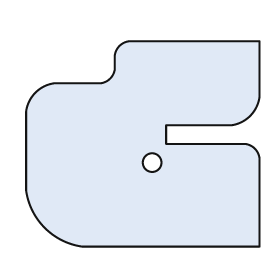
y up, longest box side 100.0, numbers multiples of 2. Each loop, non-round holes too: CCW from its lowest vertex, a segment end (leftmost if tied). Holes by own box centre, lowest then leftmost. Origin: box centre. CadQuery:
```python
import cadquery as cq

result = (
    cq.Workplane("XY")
    .moveTo(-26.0, -44.0)
    .lineTo(50.0, -44.0)
    .lineTo(50.0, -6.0)
    .threePointArc((48.0, -2.0), (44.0, 0.0))
    .lineTo(10.0, 0.0)
    .lineTo(10.0, 8.0)
    .lineTo(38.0, 8.0)
    .threePointArc((46.0, 12.0), (50.0, 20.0))
    .lineTo(50.0, 44.0)
    .lineTo(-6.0, 44.0)
    .threePointArc((-10.0, 42.0), (-12.0, 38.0))
    .lineTo(-12.0, 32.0)
    .threePointArc((-14.0, 28.0), (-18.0, 26.0))
    .lineTo(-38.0, 26.0)
    .threePointArc((-46.0, 22.0), (-50.0, 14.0))
    .lineTo(-50.0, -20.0)
    .threePointArc((-42.0, -36.0), (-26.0, -44.0))
    .close()
    .moveTo(4.0, -8.0)
    .circle(4.0)
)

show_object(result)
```